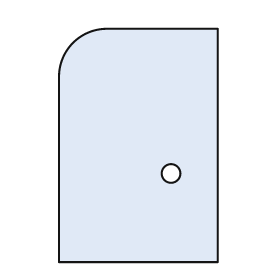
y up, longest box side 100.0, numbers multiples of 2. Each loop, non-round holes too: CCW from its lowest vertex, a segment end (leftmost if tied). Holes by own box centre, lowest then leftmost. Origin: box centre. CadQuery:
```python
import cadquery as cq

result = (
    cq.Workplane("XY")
    .moveTo(-34.0, -50.0)
    .lineTo(34.0, -50.0)
    .lineTo(34.0, 50.0)
    .lineTo(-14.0, 50.0)
    .threePointArc((-28.0, 44.0), (-34.0, 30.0))
    .close()
    .moveTo(14.0, -12.0)
    .circle(4.0)
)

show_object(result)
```